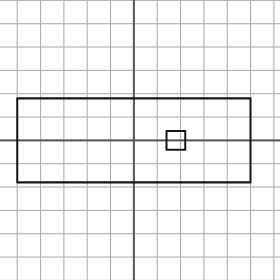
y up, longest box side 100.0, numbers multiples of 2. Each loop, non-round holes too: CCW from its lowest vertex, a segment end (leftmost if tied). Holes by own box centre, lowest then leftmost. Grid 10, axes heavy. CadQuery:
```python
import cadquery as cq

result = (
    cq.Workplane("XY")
    .moveTo(-50.0, -18.0)
    .lineTo(50.0, -18.0)
    .lineTo(50.0, 18.0)
    .lineTo(-50.0, 18.0)
    .close()
    .moveTo(14.0, -4.0)
    .lineTo(22.0, -4.0)
    .lineTo(22.0, 4.0)
    .lineTo(14.0, 4.0)
    .close()
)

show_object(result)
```